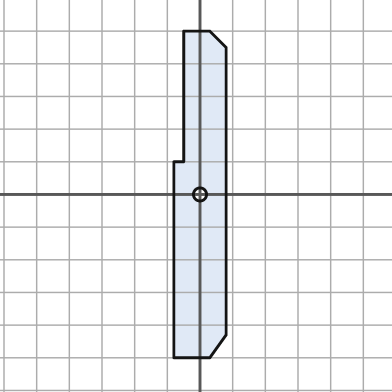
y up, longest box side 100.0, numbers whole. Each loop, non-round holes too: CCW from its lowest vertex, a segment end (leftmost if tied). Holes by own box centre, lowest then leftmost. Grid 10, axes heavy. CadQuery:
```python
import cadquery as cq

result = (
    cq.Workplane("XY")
    .moveTo(-8.0, -50.0)
    .lineTo(3.0, -50.0)
    .lineTo(8.0, -43.0)
    .lineTo(8.0, 45.0)
    .lineTo(3.0, 50.0)
    .lineTo(-5.0, 50.0)
    .lineTo(-5.0, 10.0)
    .lineTo(-8.0, 10.0)
    .close()
    .moveTo(0.0, 0.0)
    .circle(2.0)
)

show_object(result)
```